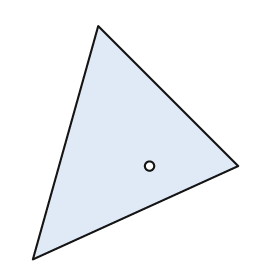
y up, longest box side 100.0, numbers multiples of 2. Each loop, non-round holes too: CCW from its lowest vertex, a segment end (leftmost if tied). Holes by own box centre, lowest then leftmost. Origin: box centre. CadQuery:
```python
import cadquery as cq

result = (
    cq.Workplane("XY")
    .moveTo(-44.0, -50.0)
    .lineTo(44.0, -10.0)
    .lineTo(-16.0, 50.0)
    .close()
    .moveTo(6.0, -10.0)
    .circle(2.0)
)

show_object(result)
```